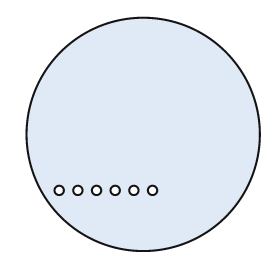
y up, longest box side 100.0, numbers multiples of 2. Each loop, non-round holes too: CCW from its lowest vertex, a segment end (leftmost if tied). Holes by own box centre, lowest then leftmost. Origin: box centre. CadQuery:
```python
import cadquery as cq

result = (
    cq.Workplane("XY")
    .moveTo(0.0, 0.0)
    .circle(50.0)
    .moveTo(-36.0, -24.0)
    .circle(2.0)
    .moveTo(-28.0, -24.0)
    .circle(2.0)
    .moveTo(-20.0, -24.0)
    .circle(2.0)
    .moveTo(-12.0, -24.0)
    .circle(2.0)
    .moveTo(-4.0, -24.0)
    .circle(2.0)
    .moveTo(4.0, -24.0)
    .circle(2.0)
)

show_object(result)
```